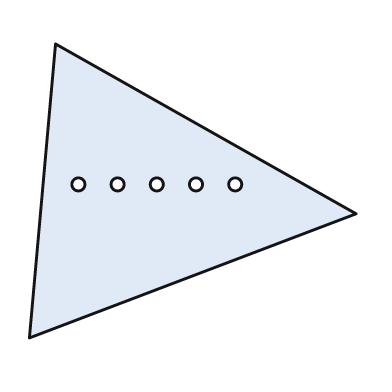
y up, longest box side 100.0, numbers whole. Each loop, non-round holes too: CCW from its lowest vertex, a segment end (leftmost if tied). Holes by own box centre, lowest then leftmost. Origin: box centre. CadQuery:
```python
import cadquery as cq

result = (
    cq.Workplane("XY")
    .moveTo(-50.0, -45.0)
    .lineTo(50.0, -7.0)
    .lineTo(-42.0, 45.0)
    .close()
    .moveTo(-35.0, 2.0)
    .circle(2.0)
    .moveTo(-23.0, 2.0)
    .circle(2.0)
    .moveTo(-11.0, 2.0)
    .circle(2.0)
    .moveTo(1.0, 2.0)
    .circle(2.0)
    .moveTo(13.0, 2.0)
    .circle(2.0)
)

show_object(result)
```